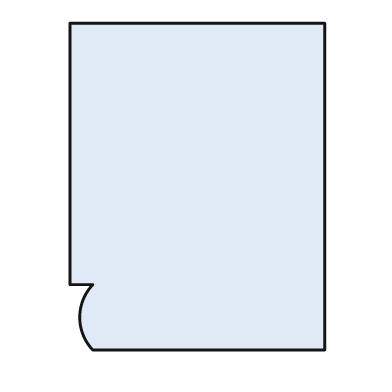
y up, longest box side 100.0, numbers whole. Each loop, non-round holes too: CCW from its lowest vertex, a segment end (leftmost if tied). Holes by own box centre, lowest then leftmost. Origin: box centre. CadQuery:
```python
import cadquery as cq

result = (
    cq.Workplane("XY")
    .moveTo(-32.0, -50.0)
    .lineTo(39.0, -50.0)
    .lineTo(39.0, 50.0)
    .lineTo(-39.0, 50.0)
    .lineTo(-39.0, -30.0)
    .lineTo(-32.0, -30.0)
    .threePointArc((-36.0, -40.0), (-32.0, -50.0))
    .close()
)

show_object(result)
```